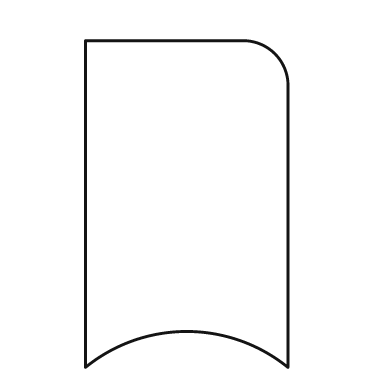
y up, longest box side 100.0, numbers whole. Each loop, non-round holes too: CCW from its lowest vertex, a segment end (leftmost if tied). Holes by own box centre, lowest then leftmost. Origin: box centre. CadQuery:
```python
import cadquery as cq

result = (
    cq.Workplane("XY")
    .moveTo(-31.0, -50.0)
    .threePointArc((0.0, -39.0), (31.0, -50.0))
    .lineTo(31.0, 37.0)
    .threePointArc((27.0, 46.0), (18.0, 50.0))
    .lineTo(-31.0, 50.0)
    .close()
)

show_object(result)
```